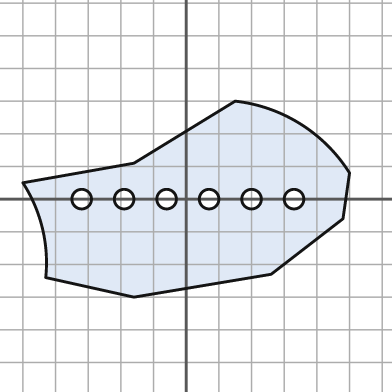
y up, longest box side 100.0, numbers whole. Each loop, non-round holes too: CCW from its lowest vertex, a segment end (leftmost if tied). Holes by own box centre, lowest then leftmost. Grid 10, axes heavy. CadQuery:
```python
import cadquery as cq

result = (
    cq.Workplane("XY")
    .moveTo(-16.0, -30.0)
    .lineTo(26.0, -23.0)
    .lineTo(48.0, -6.0)
    .lineTo(50.0, 8.0)
    .threePointArc((35.0, 23.0), (15.0, 30.0))
    .lineTo(-16.0, 11.0)
    .lineTo(-50.0, 5.0)
    .threePointArc((-44.0, -9.0), (-43.0, -24.0))
    .close()
    .moveTo(-32.0, 0.0)
    .circle(3.0)
    .moveTo(-19.0, 0.0)
    .circle(3.0)
    .moveTo(-6.0, 0.0)
    .circle(3.0)
    .moveTo(7.0, 0.0)
    .circle(3.0)
    .moveTo(20.0, 0.0)
    .circle(3.0)
    .moveTo(33.0, 0.0)
    .circle(3.0)
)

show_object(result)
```